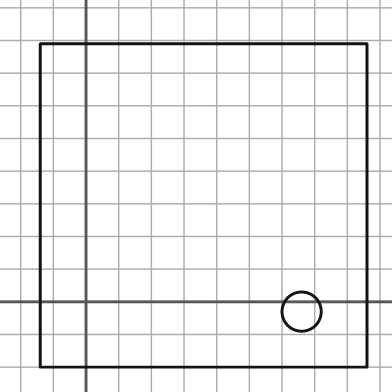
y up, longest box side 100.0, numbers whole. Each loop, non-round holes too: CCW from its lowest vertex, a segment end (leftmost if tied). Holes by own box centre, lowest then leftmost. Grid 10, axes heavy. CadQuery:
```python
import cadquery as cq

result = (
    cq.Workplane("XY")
    .moveTo(-14.0, -20.0)
    .lineTo(86.0, -20.0)
    .lineTo(86.0, 79.0)
    .lineTo(-14.0, 79.0)
    .close()
    .moveTo(66.0, -3.0)
    .circle(6.0)
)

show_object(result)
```